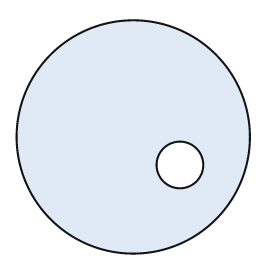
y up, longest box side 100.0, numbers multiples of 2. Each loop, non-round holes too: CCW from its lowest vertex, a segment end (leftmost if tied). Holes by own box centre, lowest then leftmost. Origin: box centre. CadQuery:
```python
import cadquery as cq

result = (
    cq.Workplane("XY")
    .moveTo(0.0, 0.0)
    .circle(50.0)
    .moveTo(20.0, -12.0)
    .circle(10.0)
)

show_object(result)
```